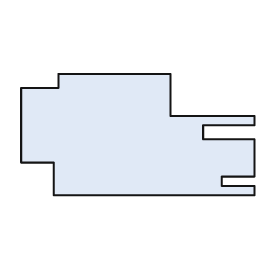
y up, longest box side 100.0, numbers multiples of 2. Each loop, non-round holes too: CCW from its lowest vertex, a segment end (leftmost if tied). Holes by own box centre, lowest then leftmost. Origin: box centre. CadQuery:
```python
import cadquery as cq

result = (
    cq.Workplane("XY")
    .moveTo(-36.0, -26.0)
    .lineTo(50.0, -26.0)
    .lineTo(50.0, -22.0)
    .lineTo(36.0, -22.0)
    .lineTo(36.0, -18.0)
    .lineTo(50.0, -18.0)
    .lineTo(50.0, -2.0)
    .lineTo(28.0, -2.0)
    .lineTo(28.0, 4.0)
    .lineTo(50.0, 4.0)
    .lineTo(50.0, 8.0)
    .lineTo(14.0, 8.0)
    .lineTo(14.0, 26.0)
    .lineTo(-34.0, 26.0)
    .lineTo(-34.0, 20.0)
    .lineTo(-50.0, 20.0)
    .lineTo(-50.0, -12.0)
    .lineTo(-36.0, -12.0)
    .close()
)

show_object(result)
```